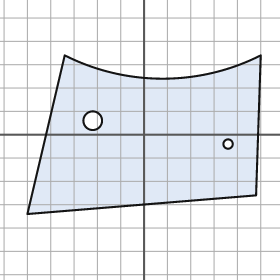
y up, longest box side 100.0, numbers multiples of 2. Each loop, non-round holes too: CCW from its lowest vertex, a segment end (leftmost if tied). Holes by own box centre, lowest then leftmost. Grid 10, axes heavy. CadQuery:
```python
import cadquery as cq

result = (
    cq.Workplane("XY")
    .moveTo(-50.0, -34.0)
    .lineTo(48.0, -26.0)
    .lineTo(50.0, 34.0)
    .threePointArc((8.0, 24.0), (-34.0, 34.0))
    .close()
    .moveTo(36.0, -4.0)
    .circle(2.0)
    .moveTo(-22.0, 6.0)
    .circle(4.0)
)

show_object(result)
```